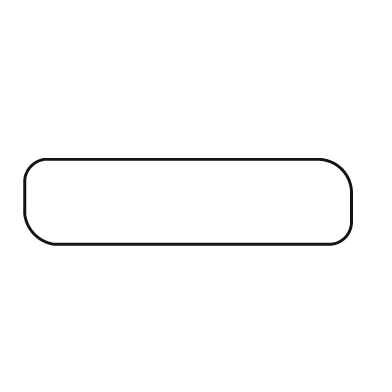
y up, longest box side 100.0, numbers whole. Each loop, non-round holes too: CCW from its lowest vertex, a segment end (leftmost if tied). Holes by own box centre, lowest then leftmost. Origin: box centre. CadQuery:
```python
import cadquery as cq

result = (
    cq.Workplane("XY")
    .moveTo(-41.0, -13.0)
    .lineTo(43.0, -13.0)
    .threePointArc((48.0, -11.0), (50.0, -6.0))
    .lineTo(50.0, 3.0)
    .threePointArc((47.0, 10.0), (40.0, 13.0))
    .lineTo(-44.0, 13.0)
    .threePointArc((-48.0, 11.0), (-50.0, 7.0))
    .lineTo(-50.0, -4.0)
    .threePointArc((-47.0, -10.0), (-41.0, -13.0))
    .close()
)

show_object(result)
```